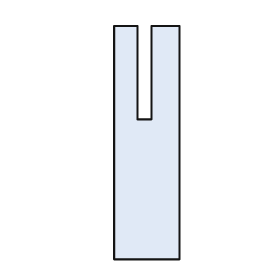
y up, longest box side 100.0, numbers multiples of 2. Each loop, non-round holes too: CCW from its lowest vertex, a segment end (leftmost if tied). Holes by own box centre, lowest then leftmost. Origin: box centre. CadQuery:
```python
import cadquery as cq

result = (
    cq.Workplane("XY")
    .moveTo(-14.0, -50.0)
    .lineTo(14.0, -50.0)
    .lineTo(14.0, 50.0)
    .lineTo(2.0, 50.0)
    .lineTo(2.0, 10.0)
    .lineTo(-4.0, 10.0)
    .lineTo(-4.0, 50.0)
    .lineTo(-14.0, 50.0)
    .close()
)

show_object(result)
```